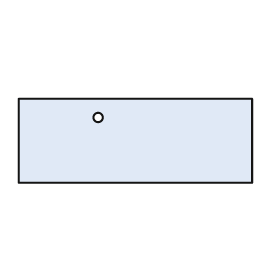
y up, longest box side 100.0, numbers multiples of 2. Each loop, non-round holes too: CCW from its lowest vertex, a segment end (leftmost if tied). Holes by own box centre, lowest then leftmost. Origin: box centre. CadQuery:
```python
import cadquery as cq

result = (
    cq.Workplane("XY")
    .moveTo(-50.0, -18.0)
    .lineTo(50.0, -18.0)
    .lineTo(50.0, 18.0)
    .lineTo(-50.0, 18.0)
    .close()
    .moveTo(-16.0, 10.0)
    .circle(2.0)
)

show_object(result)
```